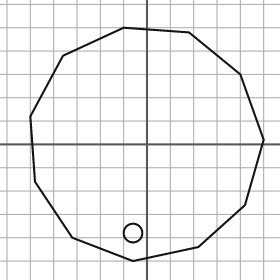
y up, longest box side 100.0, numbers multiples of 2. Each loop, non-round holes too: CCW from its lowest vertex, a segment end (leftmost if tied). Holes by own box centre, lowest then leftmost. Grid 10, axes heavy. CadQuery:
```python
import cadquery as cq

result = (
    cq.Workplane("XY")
    .moveTo(-6.0, -50.0)
    .lineTo(22.0, -44.0)
    .lineTo(42.0, -26.0)
    .lineTo(50.0, 2.0)
    .lineTo(40.0, 30.0)
    .lineTo(18.0, 48.0)
    .lineTo(-10.0, 50.0)
    .lineTo(-36.0, 38.0)
    .lineTo(-50.0, 12.0)
    .lineTo(-48.0, -16.0)
    .lineTo(-32.0, -40.0)
    .close()
    .moveTo(-6.0, -38.0)
    .circle(4.0)
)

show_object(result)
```